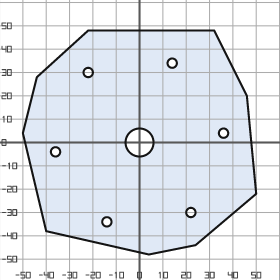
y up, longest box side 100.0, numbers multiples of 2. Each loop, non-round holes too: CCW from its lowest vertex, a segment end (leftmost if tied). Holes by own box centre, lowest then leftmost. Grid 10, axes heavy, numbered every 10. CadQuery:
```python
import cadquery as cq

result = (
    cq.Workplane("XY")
    .moveTo(4.0, -48.0)
    .lineTo(24.0, -44.0)
    .lineTo(50.0, -22.0)
    .lineTo(46.0, 20.0)
    .lineTo(32.0, 48.0)
    .lineTo(-22.0, 48.0)
    .lineTo(-44.0, 28.0)
    .lineTo(-50.0, 4.0)
    .lineTo(-40.0, -38.0)
    .close()
    .moveTo(-14.0, -34.0)
    .circle(2.0)
    .moveTo(22.0, -30.0)
    .circle(2.0)
    .moveTo(-36.0, -4.0)
    .circle(2.0)
    .moveTo(0.0, 0.0)
    .circle(6.0)
    .moveTo(36.0, 4.0)
    .circle(2.0)
    .moveTo(-22.0, 30.0)
    .circle(2.0)
    .moveTo(14.0, 34.0)
    .circle(2.0)
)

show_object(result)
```